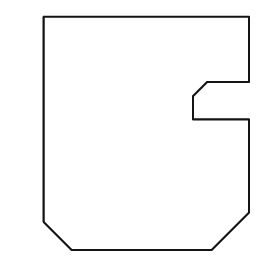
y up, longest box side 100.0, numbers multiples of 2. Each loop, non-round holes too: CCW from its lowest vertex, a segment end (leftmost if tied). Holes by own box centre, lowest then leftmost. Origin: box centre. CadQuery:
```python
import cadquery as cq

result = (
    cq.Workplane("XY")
    .moveTo(-32.0, -50.0)
    .lineTo(28.0, -50.0)
    .lineTo(44.0, -34.0)
    .lineTo(44.0, 6.0)
    .lineTo(20.0, 6.0)
    .lineTo(20.0, 16.0)
    .lineTo(26.0, 22.0)
    .lineTo(44.0, 22.0)
    .lineTo(44.0, 50.0)
    .lineTo(-44.0, 50.0)
    .lineTo(-44.0, -38.0)
    .close()
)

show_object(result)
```